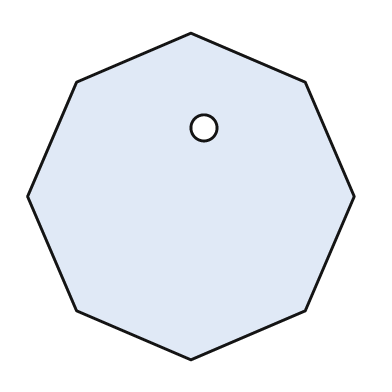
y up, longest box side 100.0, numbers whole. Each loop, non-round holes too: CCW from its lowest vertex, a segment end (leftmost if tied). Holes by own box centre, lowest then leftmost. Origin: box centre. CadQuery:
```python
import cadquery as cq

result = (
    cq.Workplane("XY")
    .moveTo(0.0, -50.0)
    .lineTo(35.0, -35.0)
    .lineTo(50.0, 0.0)
    .lineTo(35.0, 35.0)
    .lineTo(0.0, 50.0)
    .lineTo(-35.0, 35.0)
    .lineTo(-50.0, 0.0)
    .lineTo(-35.0, -35.0)
    .close()
    .moveTo(4.0, 21.0)
    .circle(4.0)
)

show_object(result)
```